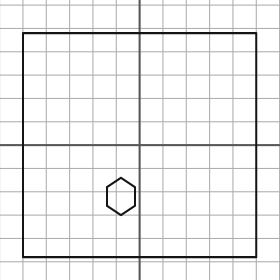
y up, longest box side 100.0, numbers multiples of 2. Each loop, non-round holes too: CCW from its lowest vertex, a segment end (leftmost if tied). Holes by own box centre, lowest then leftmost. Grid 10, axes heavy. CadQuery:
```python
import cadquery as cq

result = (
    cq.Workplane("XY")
    .moveTo(-50.0, -48.0)
    .lineTo(50.0, -48.0)
    .lineTo(50.0, 48.0)
    .lineTo(-50.0, 48.0)
    .close()
    .moveTo(-8.0, -30.0)
    .lineTo(-2.0, -26.0)
    .lineTo(-2.0, -18.0)
    .lineTo(-8.0, -14.0)
    .lineTo(-14.0, -18.0)
    .lineTo(-14.0, -26.0)
    .close()
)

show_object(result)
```